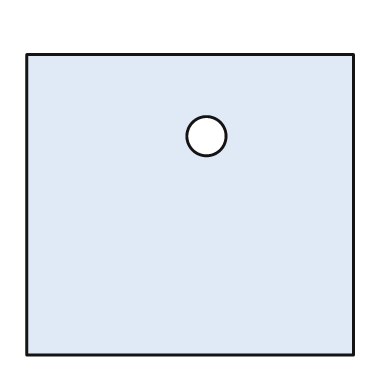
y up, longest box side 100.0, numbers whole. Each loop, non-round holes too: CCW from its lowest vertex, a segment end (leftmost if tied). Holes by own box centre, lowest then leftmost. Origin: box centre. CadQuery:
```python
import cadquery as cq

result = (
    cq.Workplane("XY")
    .moveTo(-50.0, -46.0)
    .lineTo(50.0, -46.0)
    .lineTo(50.0, 46.0)
    .lineTo(-50.0, 46.0)
    .close()
    .moveTo(5.0, 21.0)
    .circle(6.0)
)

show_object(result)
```